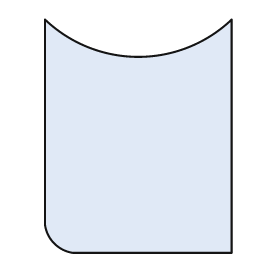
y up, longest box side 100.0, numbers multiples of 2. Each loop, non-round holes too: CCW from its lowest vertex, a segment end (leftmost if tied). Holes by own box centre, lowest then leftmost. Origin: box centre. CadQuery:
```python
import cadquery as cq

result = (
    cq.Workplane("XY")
    .moveTo(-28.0, -50.0)
    .lineTo(40.0, -50.0)
    .lineTo(40.0, 50.0)
    .threePointArc((0.0, 34.0), (-40.0, 50.0))
    .lineTo(-40.0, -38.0)
    .threePointArc((-36.0, -46.0), (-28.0, -50.0))
    .close()
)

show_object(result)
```